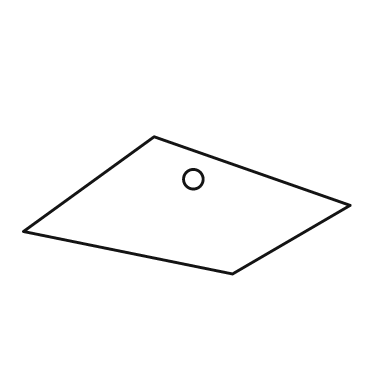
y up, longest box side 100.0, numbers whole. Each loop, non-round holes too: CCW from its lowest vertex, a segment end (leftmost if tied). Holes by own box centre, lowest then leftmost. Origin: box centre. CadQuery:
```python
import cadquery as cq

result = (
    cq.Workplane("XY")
    .moveTo(14.0, -21.0)
    .lineTo(50.0, 0.0)
    .lineTo(-10.0, 21.0)
    .lineTo(-50.0, -8.0)
    .close()
    .moveTo(2.0, 8.0)
    .circle(3.0)
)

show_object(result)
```